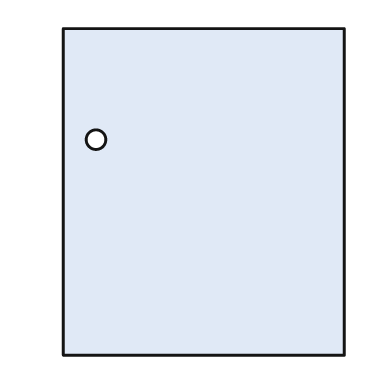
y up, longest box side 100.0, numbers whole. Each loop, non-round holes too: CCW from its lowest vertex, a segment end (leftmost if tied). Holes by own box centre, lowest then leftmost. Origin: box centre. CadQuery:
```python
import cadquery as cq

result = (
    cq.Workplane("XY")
    .moveTo(-43.0, -50.0)
    .lineTo(43.0, -50.0)
    .lineTo(43.0, 50.0)
    .lineTo(-43.0, 50.0)
    .close()
    .moveTo(-33.0, 16.0)
    .circle(3.0)
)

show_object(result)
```